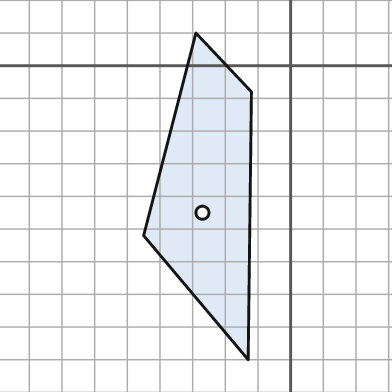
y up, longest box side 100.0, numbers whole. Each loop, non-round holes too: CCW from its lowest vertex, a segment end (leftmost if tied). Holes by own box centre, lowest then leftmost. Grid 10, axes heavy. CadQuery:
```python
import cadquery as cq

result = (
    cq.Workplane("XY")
    .moveTo(-13.0, -90.0)
    .lineTo(-12.0, -8.0)
    .lineTo(-29.0, 10.0)
    .lineTo(-45.0, -52.0)
    .close()
    .moveTo(-27.0, -45.0)
    .circle(2.0)
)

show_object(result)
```